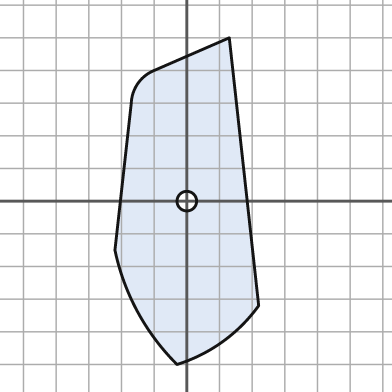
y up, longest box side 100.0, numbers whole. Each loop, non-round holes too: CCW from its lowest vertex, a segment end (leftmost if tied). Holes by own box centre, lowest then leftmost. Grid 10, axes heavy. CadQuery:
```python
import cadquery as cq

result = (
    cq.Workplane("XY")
    .moveTo(-3.0, -50.0)
    .threePointArc((11.0, -43.0), (22.0, -32.0))
    .lineTo(13.0, 50.0)
    .lineTo(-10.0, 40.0)
    .threePointArc((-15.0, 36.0), (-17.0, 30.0))
    .lineTo(-22.0, -15.0)
    .threePointArc((-15.0, -34.0), (-3.0, -50.0))
    .close()
    .moveTo(0.0, 0.0)
    .circle(3.0)
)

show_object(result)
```